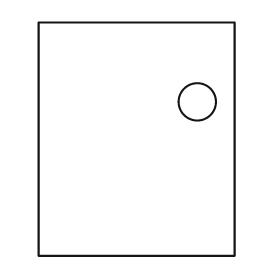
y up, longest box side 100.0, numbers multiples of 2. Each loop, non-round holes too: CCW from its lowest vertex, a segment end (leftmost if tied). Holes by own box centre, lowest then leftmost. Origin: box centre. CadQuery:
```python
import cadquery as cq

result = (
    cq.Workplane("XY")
    .moveTo(-42.0, -50.0)
    .lineTo(42.0, -50.0)
    .lineTo(42.0, 50.0)
    .lineTo(-42.0, 50.0)
    .close()
    .moveTo(26.0, 16.0)
    .circle(8.0)
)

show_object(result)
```